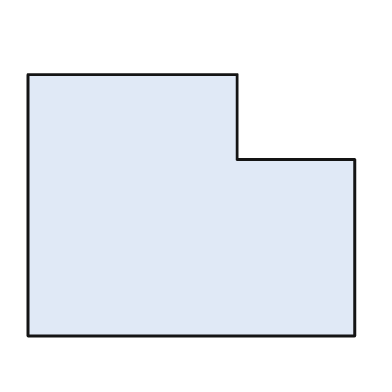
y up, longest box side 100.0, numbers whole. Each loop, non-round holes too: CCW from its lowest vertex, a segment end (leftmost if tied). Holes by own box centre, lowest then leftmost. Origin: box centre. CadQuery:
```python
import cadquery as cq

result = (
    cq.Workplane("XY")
    .moveTo(-50.0, -40.0)
    .lineTo(50.0, -40.0)
    .lineTo(50.0, 14.0)
    .lineTo(14.0, 14.0)
    .lineTo(14.0, 40.0)
    .lineTo(-50.0, 40.0)
    .close()
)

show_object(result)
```